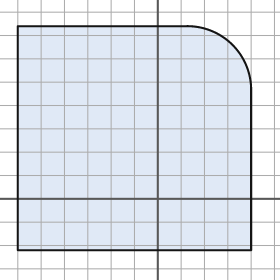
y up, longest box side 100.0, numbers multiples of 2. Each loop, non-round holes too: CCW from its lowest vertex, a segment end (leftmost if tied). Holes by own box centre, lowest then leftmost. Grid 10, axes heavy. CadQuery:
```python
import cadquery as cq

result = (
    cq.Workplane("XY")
    .moveTo(-60.0, -22.0)
    .lineTo(40.0, -22.0)
    .lineTo(40.0, 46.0)
    .threePointArc((32.0, 66.0), (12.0, 74.0))
    .lineTo(-60.0, 74.0)
    .close()
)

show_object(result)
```